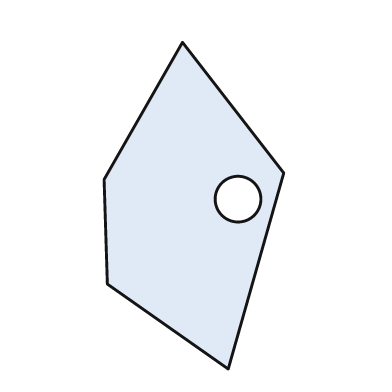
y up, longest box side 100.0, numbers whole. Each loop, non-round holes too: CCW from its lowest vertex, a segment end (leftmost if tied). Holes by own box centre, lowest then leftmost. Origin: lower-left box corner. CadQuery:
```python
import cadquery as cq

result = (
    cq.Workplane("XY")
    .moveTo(38.0, 0.0)
    .lineTo(55.0, 60.0)
    .lineTo(24.0, 100.0)
    .lineTo(0.0, 58.0)
    .lineTo(1.0, 26.0)
    .close()
    .moveTo(41.0, 52.0)
    .circle(7.0)
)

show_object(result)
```